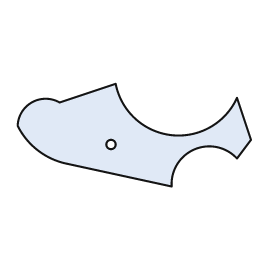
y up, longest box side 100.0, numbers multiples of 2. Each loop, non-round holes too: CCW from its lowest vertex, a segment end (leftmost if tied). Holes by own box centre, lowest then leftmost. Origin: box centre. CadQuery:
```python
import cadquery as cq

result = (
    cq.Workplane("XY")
    .moveTo(16.0, -22.0)
    .threePointArc((26.0, -6.0), (44.0, -10.0))
    .lineTo(50.0, -2.0)
    .lineTo(44.0, 16.0)
    .threePointArc((16.0, 0.0), (-8.0, 22.0))
    .lineTo(-32.0, 14.0)
    .threePointArc((-44.0, 14.0), (-50.0, 4.0))
    .threePointArc((-42.0, -6.0), (-30.0, -12.0))
    .close()
    .moveTo(-10.0, -4.0)
    .circle(2.0)
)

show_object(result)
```